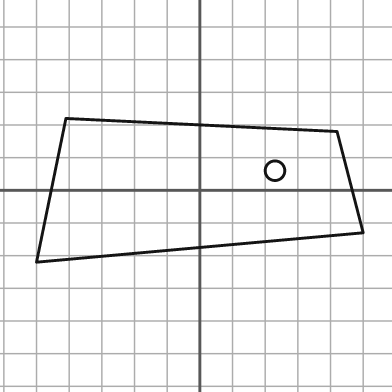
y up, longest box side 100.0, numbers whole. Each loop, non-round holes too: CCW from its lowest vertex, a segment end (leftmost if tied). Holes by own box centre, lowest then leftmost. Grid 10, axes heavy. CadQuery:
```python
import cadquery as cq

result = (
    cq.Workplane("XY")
    .moveTo(-50.0, -22.0)
    .lineTo(50.0, -13.0)
    .lineTo(42.0, 18.0)
    .lineTo(-41.0, 22.0)
    .close()
    .moveTo(23.0, 6.0)
    .circle(3.0)
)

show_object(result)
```